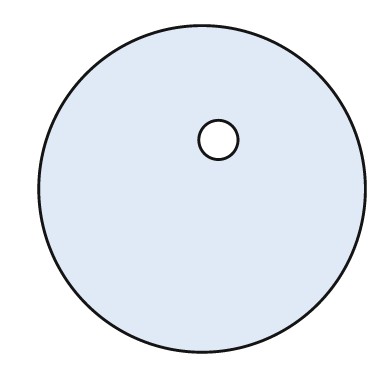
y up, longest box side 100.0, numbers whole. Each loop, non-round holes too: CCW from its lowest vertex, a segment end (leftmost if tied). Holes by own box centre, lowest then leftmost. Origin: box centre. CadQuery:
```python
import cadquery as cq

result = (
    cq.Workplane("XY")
    .moveTo(0.0, 0.0)
    .circle(50.0)
    .moveTo(5.0, 15.0)
    .circle(6.0)
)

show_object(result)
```